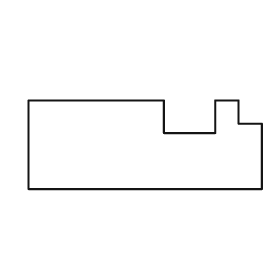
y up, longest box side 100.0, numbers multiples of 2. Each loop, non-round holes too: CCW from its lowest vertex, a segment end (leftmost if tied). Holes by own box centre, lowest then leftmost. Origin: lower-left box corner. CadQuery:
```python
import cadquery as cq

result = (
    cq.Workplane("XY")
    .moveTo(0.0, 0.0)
    .lineTo(100.0, 0.0)
    .lineTo(100.0, 28.0)
    .lineTo(90.0, 28.0)
    .lineTo(90.0, 38.0)
    .lineTo(80.0, 38.0)
    .lineTo(80.0, 24.0)
    .lineTo(58.0, 24.0)
    .lineTo(58.0, 38.0)
    .lineTo(0.0, 38.0)
    .close()
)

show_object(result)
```